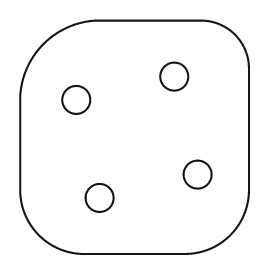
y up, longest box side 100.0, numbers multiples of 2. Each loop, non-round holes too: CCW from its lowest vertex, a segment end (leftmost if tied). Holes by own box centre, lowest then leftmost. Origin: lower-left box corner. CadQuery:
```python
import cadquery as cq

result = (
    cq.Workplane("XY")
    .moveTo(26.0, 0.0)
    .lineTo(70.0, 0.0)
    .threePointArc((90.0, 8.0), (98.0, 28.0))
    .lineTo(98.0, 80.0)
    .threePointArc((92.0, 94.0), (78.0, 100.0))
    .lineTo(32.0, 100.0)
    .threePointArc((10.0, 90.0), (0.0, 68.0))
    .lineTo(0.0, 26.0)
    .threePointArc((8.0, 8.0), (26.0, 0.0))
    .close()
    .moveTo(34.0, 24.0)
    .circle(6.0)
    .moveTo(76.0, 34.0)
    .circle(6.0)
    .moveTo(24.0, 66.0)
    .circle(6.0)
    .moveTo(66.0, 76.0)
    .circle(6.0)
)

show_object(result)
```